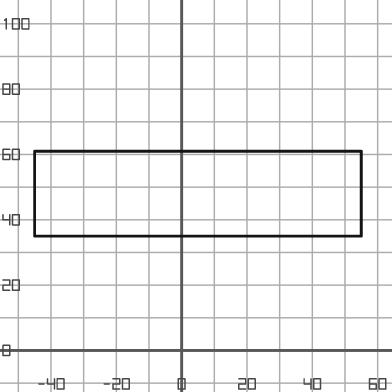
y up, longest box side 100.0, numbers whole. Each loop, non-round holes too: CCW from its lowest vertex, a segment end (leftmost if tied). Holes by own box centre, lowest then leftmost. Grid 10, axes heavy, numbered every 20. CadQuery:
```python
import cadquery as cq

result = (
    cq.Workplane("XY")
    .moveTo(-45.0, 35.0)
    .lineTo(55.0, 35.0)
    .lineTo(55.0, 61.0)
    .lineTo(-45.0, 61.0)
    .close()
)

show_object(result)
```